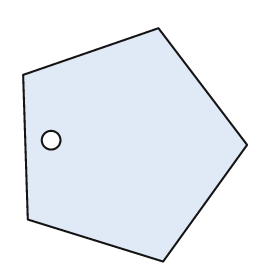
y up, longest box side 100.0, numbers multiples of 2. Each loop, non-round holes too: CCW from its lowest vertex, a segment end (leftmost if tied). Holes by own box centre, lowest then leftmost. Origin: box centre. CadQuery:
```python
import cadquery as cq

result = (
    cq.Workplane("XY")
    .moveTo(12.0, -50.0)
    .lineTo(48.0, 0.0)
    .lineTo(10.0, 50.0)
    .lineTo(-48.0, 30.0)
    .lineTo(-46.0, -32.0)
    .close()
    .moveTo(-36.0, 2.0)
    .circle(4.0)
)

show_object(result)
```